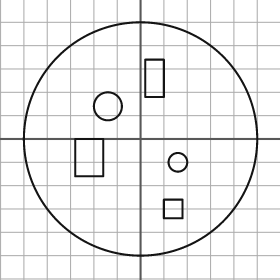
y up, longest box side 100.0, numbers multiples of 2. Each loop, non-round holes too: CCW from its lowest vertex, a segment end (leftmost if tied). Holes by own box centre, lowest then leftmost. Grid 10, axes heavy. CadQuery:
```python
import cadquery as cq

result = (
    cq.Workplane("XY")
    .moveTo(0.0, 0.0)
    .circle(50.0)
    .moveTo(10.0, -34.0)
    .lineTo(18.0, -34.0)
    .lineTo(18.0, -26.0)
    .lineTo(10.0, -26.0)
    .close()
    .moveTo(16.0, -10.0)
    .circle(4.0)
    .moveTo(-28.0, -16.0)
    .lineTo(-16.0, -16.0)
    .lineTo(-16.0, 0.0)
    .lineTo(-28.0, 0.0)
    .close()
    .moveTo(-14.0, 14.0)
    .circle(6.0)
    .moveTo(2.0, 18.0)
    .lineTo(10.0, 18.0)
    .lineTo(10.0, 34.0)
    .lineTo(2.0, 34.0)
    .close()
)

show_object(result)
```